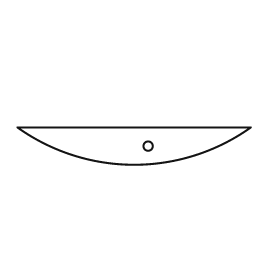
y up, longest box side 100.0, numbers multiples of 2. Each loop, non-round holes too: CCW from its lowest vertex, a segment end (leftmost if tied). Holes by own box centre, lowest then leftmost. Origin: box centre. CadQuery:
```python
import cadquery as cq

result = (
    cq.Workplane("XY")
    .moveTo(-50.0, 8.0)
    .threePointArc((0.0, -8.0), (50.0, 8.0))
    .close()
    .moveTo(6.0, 0.0)
    .circle(2.0)
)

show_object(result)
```